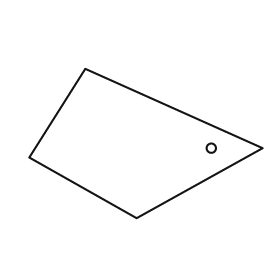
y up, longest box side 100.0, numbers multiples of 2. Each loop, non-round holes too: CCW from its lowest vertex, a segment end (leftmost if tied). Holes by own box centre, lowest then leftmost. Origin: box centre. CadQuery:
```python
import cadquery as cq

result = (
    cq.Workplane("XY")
    .moveTo(-4.0, -32.0)
    .lineTo(50.0, -2.0)
    .lineTo(-26.0, 32.0)
    .lineTo(-50.0, -6.0)
    .close()
    .moveTo(28.0, -2.0)
    .circle(2.0)
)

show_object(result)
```